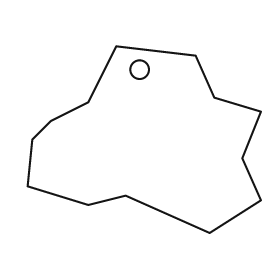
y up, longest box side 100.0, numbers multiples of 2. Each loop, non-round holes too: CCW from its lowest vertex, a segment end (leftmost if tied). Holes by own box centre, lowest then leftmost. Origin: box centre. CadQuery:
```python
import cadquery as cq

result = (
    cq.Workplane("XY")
    .moveTo(28.0, -40.0)
    .lineTo(50.0, -26.0)
    .lineTo(42.0, -8.0)
    .lineTo(50.0, 12.0)
    .lineTo(30.0, 18.0)
    .lineTo(22.0, 36.0)
    .lineTo(-12.0, 40.0)
    .lineTo(-24.0, 16.0)
    .lineTo(-40.0, 8.0)
    .lineTo(-48.0, 0.0)
    .lineTo(-50.0, -20.0)
    .lineTo(-24.0, -28.0)
    .lineTo(-8.0, -24.0)
    .close()
    .moveTo(-2.0, 30.0)
    .circle(4.0)
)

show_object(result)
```